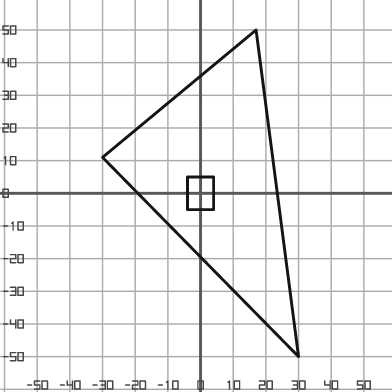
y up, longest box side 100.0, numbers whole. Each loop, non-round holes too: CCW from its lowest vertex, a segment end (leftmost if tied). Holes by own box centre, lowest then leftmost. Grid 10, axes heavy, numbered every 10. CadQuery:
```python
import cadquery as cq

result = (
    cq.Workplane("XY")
    .moveTo(30.0, -50.0)
    .lineTo(17.0, 50.0)
    .lineTo(-30.0, 11.0)
    .close()
    .moveTo(-4.0, -5.0)
    .lineTo(4.0, -5.0)
    .lineTo(4.0, 5.0)
    .lineTo(-4.0, 5.0)
    .close()
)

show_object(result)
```